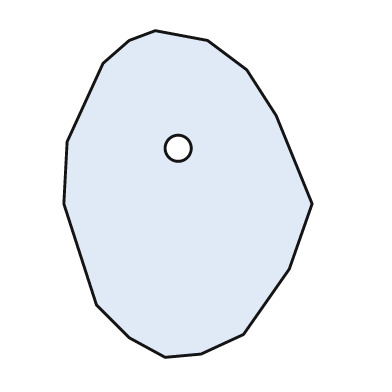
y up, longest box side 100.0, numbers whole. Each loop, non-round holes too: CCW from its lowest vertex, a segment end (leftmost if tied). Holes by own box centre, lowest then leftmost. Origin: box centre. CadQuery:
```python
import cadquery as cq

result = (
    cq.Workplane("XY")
    .moveTo(-7.0, -50.0)
    .lineTo(4.0, -49.0)
    .lineTo(17.0, -43.0)
    .lineTo(31.0, -23.0)
    .lineTo(38.0, -3.0)
    .lineTo(27.0, 24.0)
    .lineTo(18.0, 38.0)
    .lineTo(6.0, 47.0)
    .lineTo(-10.0, 50.0)
    .lineTo(-18.0, 47.0)
    .lineTo(-26.0, 40.0)
    .lineTo(-37.0, 16.0)
    .lineTo(-38.0, -3.0)
    .lineTo(-28.0, -34.0)
    .lineTo(-18.0, -44.0)
    .close()
    .moveTo(-3.0, 14.0)
    .circle(4.0)
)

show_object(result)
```